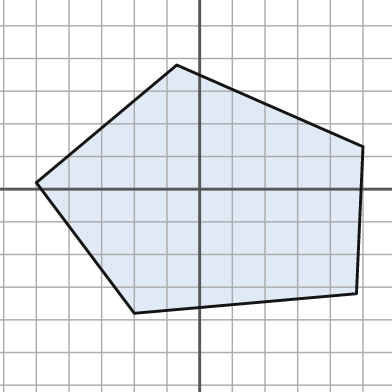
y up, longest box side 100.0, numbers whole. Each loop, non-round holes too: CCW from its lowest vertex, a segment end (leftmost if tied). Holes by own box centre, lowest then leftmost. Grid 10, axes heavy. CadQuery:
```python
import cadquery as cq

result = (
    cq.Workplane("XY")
    .moveTo(-20.0, -38.0)
    .lineTo(48.0, -32.0)
    .lineTo(50.0, 13.0)
    .lineTo(-7.0, 38.0)
    .lineTo(-50.0, 2.0)
    .close()
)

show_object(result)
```